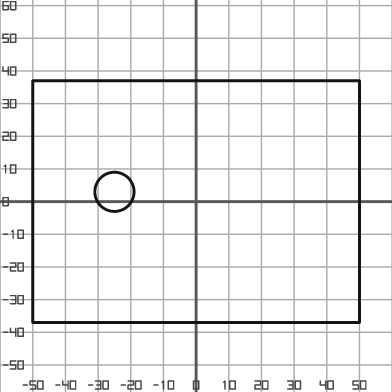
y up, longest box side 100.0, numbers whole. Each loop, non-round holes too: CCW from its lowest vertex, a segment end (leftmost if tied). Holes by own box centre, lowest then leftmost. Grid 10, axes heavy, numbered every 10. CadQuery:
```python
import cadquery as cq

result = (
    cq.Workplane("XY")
    .moveTo(-50.0, -37.0)
    .lineTo(50.0, -37.0)
    .lineTo(50.0, 37.0)
    .lineTo(-50.0, 37.0)
    .close()
    .moveTo(-25.0, 3.0)
    .circle(6.0)
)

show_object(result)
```